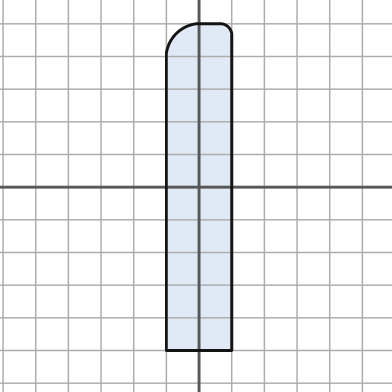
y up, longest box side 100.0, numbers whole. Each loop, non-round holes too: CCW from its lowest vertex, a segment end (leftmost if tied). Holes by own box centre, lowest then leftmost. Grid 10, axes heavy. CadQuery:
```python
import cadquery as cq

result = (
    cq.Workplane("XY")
    .moveTo(-10.0, -50.0)
    .lineTo(10.0, -50.0)
    .lineTo(10.0, 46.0)
    .threePointArc((9.0, 49.0), (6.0, 50.0))
    .lineTo(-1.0, 50.0)
    .threePointArc((-7.0, 47.0), (-10.0, 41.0))
    .close()
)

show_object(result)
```